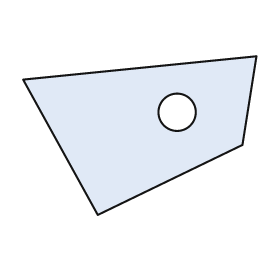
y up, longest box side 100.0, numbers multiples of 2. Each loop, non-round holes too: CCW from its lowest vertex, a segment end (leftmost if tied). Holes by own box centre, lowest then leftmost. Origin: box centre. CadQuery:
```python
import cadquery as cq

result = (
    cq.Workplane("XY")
    .moveTo(-18.0, -34.0)
    .lineTo(44.0, -4.0)
    .lineTo(50.0, 34.0)
    .lineTo(-50.0, 24.0)
    .close()
    .moveTo(16.0, 10.0)
    .circle(8.0)
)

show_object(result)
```